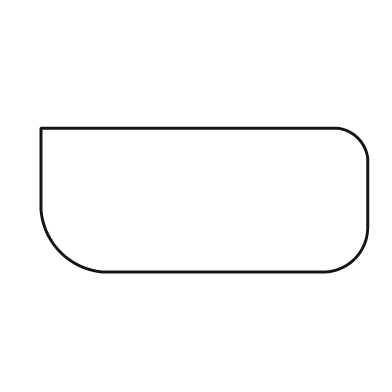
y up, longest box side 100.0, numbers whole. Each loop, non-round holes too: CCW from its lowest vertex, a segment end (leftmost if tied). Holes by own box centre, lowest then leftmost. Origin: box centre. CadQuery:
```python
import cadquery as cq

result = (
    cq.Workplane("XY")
    .moveTo(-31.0, -22.0)
    .lineTo(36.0, -22.0)
    .threePointArc((46.0, -18.0), (50.0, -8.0))
    .lineTo(50.0, 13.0)
    .threePointArc((47.0, 19.0), (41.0, 22.0))
    .lineTo(-50.0, 22.0)
    .lineTo(-50.0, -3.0)
    .threePointArc((-44.0, -16.0), (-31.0, -22.0))
    .close()
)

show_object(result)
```